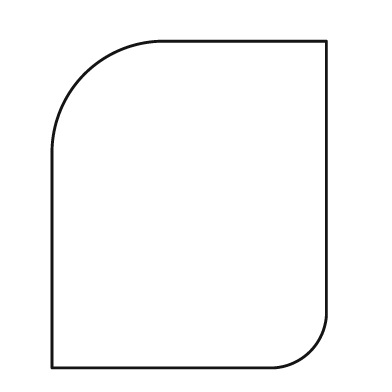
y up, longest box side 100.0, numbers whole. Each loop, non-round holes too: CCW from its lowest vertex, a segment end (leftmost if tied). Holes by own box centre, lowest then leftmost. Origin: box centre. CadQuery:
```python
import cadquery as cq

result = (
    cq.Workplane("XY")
    .moveTo(-42.0, -50.0)
    .lineTo(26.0, -50.0)
    .threePointArc((37.0, -45.0), (42.0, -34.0))
    .lineTo(42.0, 50.0)
    .lineTo(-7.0, 50.0)
    .threePointArc((-32.0, 40.0), (-42.0, 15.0))
    .close()
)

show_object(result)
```